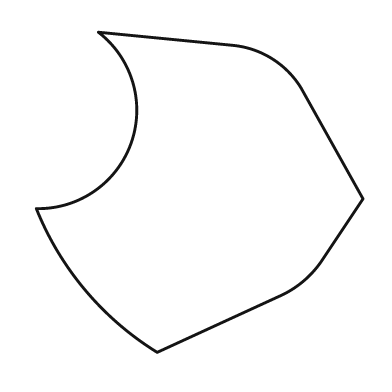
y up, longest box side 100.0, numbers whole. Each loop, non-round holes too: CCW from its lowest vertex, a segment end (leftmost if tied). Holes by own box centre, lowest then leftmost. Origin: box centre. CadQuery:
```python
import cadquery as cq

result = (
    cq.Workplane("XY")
    .moveTo(-13.0, -49.0)
    .lineTo(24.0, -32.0)
    .threePointArc((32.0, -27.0), (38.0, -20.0))
    .lineTo(50.0, -2.0)
    .lineTo(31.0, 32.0)
    .threePointArc((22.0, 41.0), (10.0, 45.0))
    .lineTo(-31.0, 49.0)
    .threePointArc((-21.0, 15.0), (-50.0, -5.0))
    .threePointArc((-35.0, -30.0), (-13.0, -49.0))
    .close()
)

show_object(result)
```